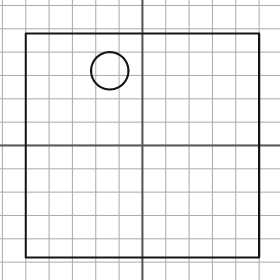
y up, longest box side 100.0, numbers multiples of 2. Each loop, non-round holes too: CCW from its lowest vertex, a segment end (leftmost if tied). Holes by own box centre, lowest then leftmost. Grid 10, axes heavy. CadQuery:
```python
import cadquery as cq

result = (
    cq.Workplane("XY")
    .moveTo(-50.0, -48.0)
    .lineTo(50.0, -48.0)
    .lineTo(50.0, 48.0)
    .lineTo(-50.0, 48.0)
    .close()
    .moveTo(-14.0, 32.0)
    .circle(8.0)
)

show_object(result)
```